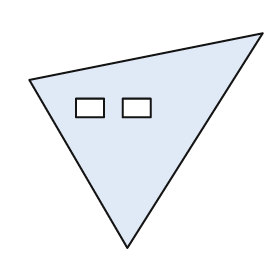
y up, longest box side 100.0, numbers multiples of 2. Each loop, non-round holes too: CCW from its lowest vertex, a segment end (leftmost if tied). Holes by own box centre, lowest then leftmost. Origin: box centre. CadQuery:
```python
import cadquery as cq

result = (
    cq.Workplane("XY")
    .moveTo(-8.0, -46.0)
    .lineTo(50.0, 46.0)
    .lineTo(-50.0, 26.0)
    .close()
    .moveTo(-30.0, 10.0)
    .lineTo(-18.0, 10.0)
    .lineTo(-18.0, 18.0)
    .lineTo(-30.0, 18.0)
    .close()
    .moveTo(-10.0, 10.0)
    .lineTo(2.0, 10.0)
    .lineTo(2.0, 18.0)
    .lineTo(-10.0, 18.0)
    .close()
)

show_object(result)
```